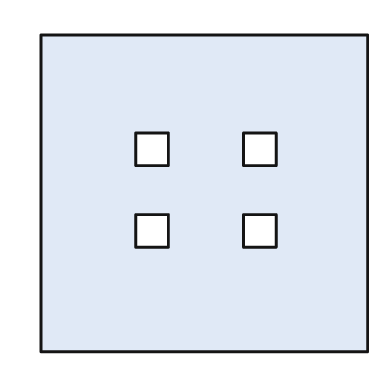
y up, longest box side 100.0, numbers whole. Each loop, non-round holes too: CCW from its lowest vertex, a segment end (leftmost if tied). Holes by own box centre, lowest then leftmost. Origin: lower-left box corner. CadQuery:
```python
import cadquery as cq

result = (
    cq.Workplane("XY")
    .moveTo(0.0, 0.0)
    .lineTo(100.0, 0.0)
    .lineTo(100.0, 97.0)
    .lineTo(0.0, 97.0)
    .close()
    .moveTo(29.0, 32.0)
    .lineTo(39.0, 32.0)
    .lineTo(39.0, 42.0)
    .lineTo(29.0, 42.0)
    .close()
    .moveTo(62.0, 32.0)
    .lineTo(72.0, 32.0)
    .lineTo(72.0, 42.0)
    .lineTo(62.0, 42.0)
    .close()
    .moveTo(29.0, 57.0)
    .lineTo(39.0, 57.0)
    .lineTo(39.0, 67.0)
    .lineTo(29.0, 67.0)
    .close()
    .moveTo(62.0, 57.0)
    .lineTo(72.0, 57.0)
    .lineTo(72.0, 67.0)
    .lineTo(62.0, 67.0)
    .close()
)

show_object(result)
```